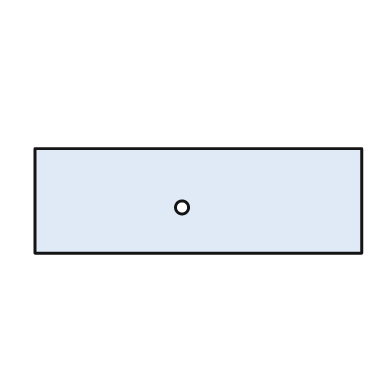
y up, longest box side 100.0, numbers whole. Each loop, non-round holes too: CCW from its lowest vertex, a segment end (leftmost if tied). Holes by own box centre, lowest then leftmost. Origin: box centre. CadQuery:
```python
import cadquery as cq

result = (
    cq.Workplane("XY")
    .moveTo(-50.0, -16.0)
    .lineTo(50.0, -16.0)
    .lineTo(50.0, 16.0)
    .lineTo(-50.0, 16.0)
    .close()
    .moveTo(-5.0, -2.0)
    .circle(2.0)
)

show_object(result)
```